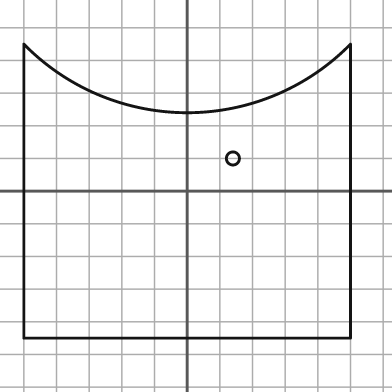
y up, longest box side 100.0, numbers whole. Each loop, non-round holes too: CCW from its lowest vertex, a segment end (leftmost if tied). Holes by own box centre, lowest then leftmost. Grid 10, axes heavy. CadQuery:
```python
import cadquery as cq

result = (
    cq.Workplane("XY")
    .moveTo(-50.0, -45.0)
    .lineTo(50.0, -45.0)
    .lineTo(50.0, 45.0)
    .threePointArc((0.0, 24.0), (-50.0, 45.0))
    .close()
    .moveTo(14.0, 10.0)
    .circle(2.0)
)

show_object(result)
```